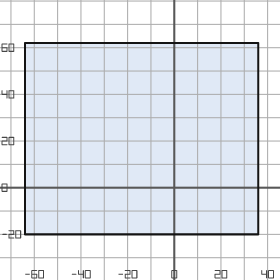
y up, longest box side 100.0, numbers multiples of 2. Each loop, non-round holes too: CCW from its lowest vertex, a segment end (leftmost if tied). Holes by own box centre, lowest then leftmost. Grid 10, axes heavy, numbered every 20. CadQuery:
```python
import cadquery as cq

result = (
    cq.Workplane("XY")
    .moveTo(-64.0, -20.0)
    .lineTo(36.0, -20.0)
    .lineTo(36.0, 62.0)
    .lineTo(-64.0, 62.0)
    .close()
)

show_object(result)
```